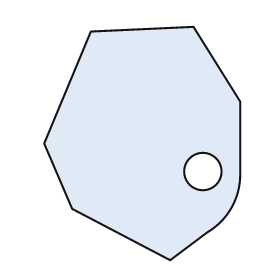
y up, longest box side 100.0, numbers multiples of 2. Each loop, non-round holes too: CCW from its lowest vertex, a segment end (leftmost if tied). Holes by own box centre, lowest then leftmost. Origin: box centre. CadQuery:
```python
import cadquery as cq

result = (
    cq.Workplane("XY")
    .moveTo(12.0, -50.0)
    .lineTo(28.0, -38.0)
    .threePointArc((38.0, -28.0), (42.0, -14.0))
    .lineTo(42.0, 18.0)
    .lineTo(22.0, 50.0)
    .lineTo(-22.0, 48.0)
    .lineTo(-42.0, 0.0)
    .lineTo(-30.0, -28.0)
    .close()
    .moveTo(26.0, -12.0)
    .circle(8.0)
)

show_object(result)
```